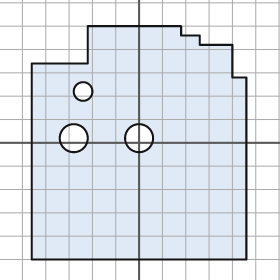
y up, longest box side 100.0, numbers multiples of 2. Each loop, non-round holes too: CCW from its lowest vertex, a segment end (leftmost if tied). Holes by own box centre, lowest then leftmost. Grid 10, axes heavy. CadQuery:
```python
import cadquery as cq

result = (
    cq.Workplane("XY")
    .moveTo(-46.0, -50.0)
    .lineTo(46.0, -50.0)
    .lineTo(46.0, 28.0)
    .lineTo(40.0, 28.0)
    .lineTo(40.0, 42.0)
    .lineTo(26.0, 42.0)
    .lineTo(26.0, 46.0)
    .lineTo(18.0, 46.0)
    .lineTo(18.0, 50.0)
    .lineTo(-22.0, 50.0)
    .lineTo(-22.0, 34.0)
    .lineTo(-46.0, 34.0)
    .close()
    .moveTo(-28.0, 2.0)
    .circle(6.0)
    .moveTo(0.0, 2.0)
    .circle(6.0)
    .moveTo(-24.0, 22.0)
    .circle(4.0)
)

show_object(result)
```